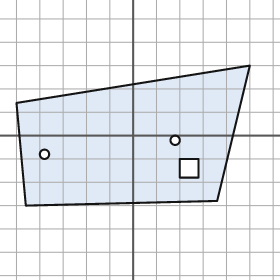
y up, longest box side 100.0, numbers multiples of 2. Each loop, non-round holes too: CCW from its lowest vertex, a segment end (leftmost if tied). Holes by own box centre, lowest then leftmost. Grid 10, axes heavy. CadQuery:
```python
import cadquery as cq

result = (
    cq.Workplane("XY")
    .moveTo(-46.0, -30.0)
    .lineTo(36.0, -28.0)
    .lineTo(50.0, 30.0)
    .lineTo(-50.0, 14.0)
    .close()
    .moveTo(20.0, -18.0)
    .lineTo(28.0, -18.0)
    .lineTo(28.0, -10.0)
    .lineTo(20.0, -10.0)
    .close()
    .moveTo(-38.0, -8.0)
    .circle(2.0)
    .moveTo(18.0, -2.0)
    .circle(2.0)
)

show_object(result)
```